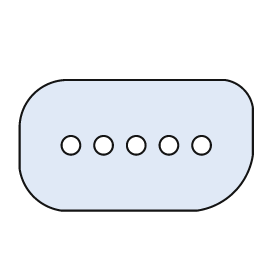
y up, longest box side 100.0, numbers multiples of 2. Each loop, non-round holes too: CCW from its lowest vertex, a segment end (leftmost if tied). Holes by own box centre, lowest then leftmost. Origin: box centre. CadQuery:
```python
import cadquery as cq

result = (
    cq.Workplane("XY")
    .moveTo(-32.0, -28.0)
    .lineTo(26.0, -28.0)
    .threePointArc((42.0, -20.0), (50.0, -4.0))
    .lineTo(50.0, 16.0)
    .threePointArc((46.0, 24.0), (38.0, 28.0))
    .lineTo(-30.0, 28.0)
    .threePointArc((-44.0, 22.0), (-50.0, 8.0))
    .lineTo(-50.0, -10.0)
    .threePointArc((-44.0, -22.0), (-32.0, -28.0))
    .close()
    .moveTo(-28.0, 0.0)
    .circle(4.0)
    .moveTo(-14.0, 0.0)
    .circle(4.0)
    .moveTo(0.0, 0.0)
    .circle(4.0)
    .moveTo(14.0, 0.0)
    .circle(4.0)
    .moveTo(28.0, 0.0)
    .circle(4.0)
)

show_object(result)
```